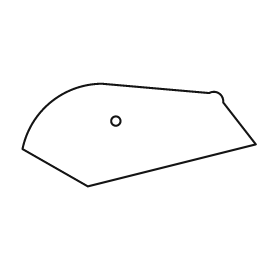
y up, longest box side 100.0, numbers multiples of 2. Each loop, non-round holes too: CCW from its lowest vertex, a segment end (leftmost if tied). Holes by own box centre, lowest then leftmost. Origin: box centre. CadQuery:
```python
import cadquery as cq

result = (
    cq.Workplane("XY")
    .moveTo(-22.0, -22.0)
    .lineTo(50.0, -4.0)
    .lineTo(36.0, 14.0)
    .threePointArc((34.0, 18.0), (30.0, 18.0))
    .lineTo(-16.0, 22.0)
    .threePointArc((-38.0, 14.0), (-50.0, -6.0))
    .close()
    .moveTo(-10.0, 6.0)
    .circle(2.0)
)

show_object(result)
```